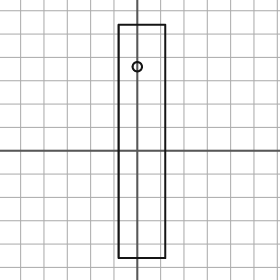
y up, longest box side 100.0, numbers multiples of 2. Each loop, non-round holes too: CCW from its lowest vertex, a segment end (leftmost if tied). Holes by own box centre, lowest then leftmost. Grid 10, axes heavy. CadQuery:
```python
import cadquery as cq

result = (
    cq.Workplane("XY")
    .moveTo(-8.0, -46.0)
    .lineTo(12.0, -46.0)
    .lineTo(12.0, 54.0)
    .lineTo(-8.0, 54.0)
    .close()
    .moveTo(0.0, 36.0)
    .circle(2.0)
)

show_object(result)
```